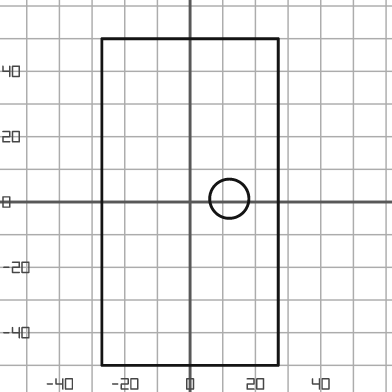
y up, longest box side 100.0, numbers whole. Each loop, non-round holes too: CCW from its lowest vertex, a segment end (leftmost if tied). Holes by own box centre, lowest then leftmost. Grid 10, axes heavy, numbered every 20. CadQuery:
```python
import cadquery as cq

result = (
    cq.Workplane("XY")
    .moveTo(-27.0, -50.0)
    .lineTo(27.0, -50.0)
    .lineTo(27.0, 50.0)
    .lineTo(-27.0, 50.0)
    .close()
    .moveTo(12.0, 1.0)
    .circle(6.0)
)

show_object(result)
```